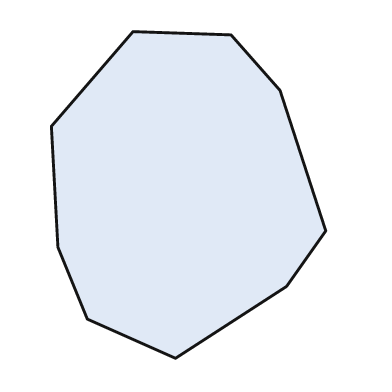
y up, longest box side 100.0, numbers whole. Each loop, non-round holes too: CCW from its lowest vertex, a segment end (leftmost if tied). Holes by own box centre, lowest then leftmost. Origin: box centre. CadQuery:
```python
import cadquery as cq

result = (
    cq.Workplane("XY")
    .moveTo(-4.0, -50.0)
    .lineTo(30.0, -28.0)
    .lineTo(42.0, -11.0)
    .lineTo(28.0, 32.0)
    .lineTo(13.0, 49.0)
    .lineTo(-17.0, 50.0)
    .lineTo(-42.0, 21.0)
    .lineTo(-40.0, -16.0)
    .lineTo(-31.0, -38.0)
    .close()
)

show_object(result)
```